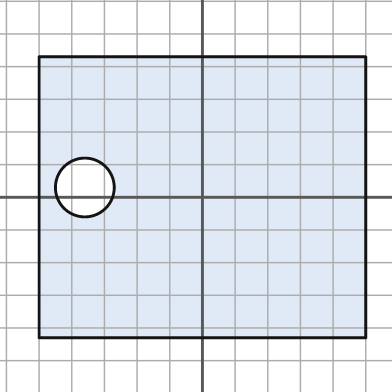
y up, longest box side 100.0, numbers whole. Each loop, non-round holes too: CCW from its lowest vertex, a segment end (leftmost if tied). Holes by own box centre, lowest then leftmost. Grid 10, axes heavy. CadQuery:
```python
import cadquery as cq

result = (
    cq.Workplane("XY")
    .moveTo(-50.0, -43.0)
    .lineTo(50.0, -43.0)
    .lineTo(50.0, 43.0)
    .lineTo(-50.0, 43.0)
    .close()
    .moveTo(-36.0, 3.0)
    .circle(9.0)
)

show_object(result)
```